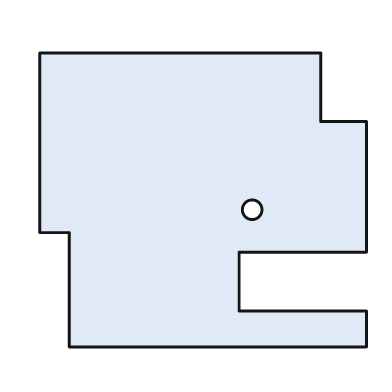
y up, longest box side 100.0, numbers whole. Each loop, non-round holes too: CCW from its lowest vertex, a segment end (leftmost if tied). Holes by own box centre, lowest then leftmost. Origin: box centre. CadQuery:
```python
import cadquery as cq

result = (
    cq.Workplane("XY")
    .moveTo(-41.0, -45.0)
    .lineTo(50.0, -45.0)
    .lineTo(50.0, -34.0)
    .lineTo(11.0, -34.0)
    .lineTo(11.0, -16.0)
    .lineTo(50.0, -16.0)
    .lineTo(50.0, 24.0)
    .lineTo(36.0, 24.0)
    .lineTo(36.0, 45.0)
    .lineTo(-50.0, 45.0)
    .lineTo(-50.0, -10.0)
    .lineTo(-41.0, -10.0)
    .close()
    .moveTo(15.0, -3.0)
    .circle(3.0)
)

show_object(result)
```